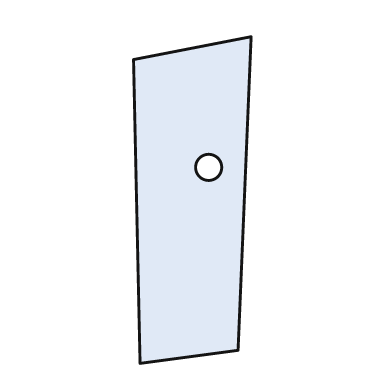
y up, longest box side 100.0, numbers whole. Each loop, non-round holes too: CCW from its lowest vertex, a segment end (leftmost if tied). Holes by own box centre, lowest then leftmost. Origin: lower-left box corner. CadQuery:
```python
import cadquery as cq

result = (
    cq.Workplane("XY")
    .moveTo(2.0, 0.0)
    .lineTo(32.0, 4.0)
    .lineTo(36.0, 100.0)
    .lineTo(0.0, 93.0)
    .close()
    .moveTo(23.0, 60.0)
    .circle(4.0)
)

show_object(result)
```